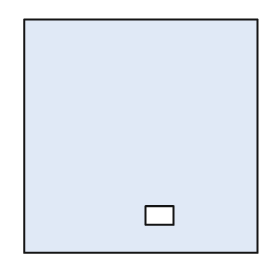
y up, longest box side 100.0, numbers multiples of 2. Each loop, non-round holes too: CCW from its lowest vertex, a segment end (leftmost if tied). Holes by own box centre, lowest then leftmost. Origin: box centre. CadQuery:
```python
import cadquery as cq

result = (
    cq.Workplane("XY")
    .moveTo(-50.0, -50.0)
    .lineTo(50.0, -50.0)
    .lineTo(50.0, 50.0)
    .lineTo(-50.0, 50.0)
    .close()
    .moveTo(2.0, -38.0)
    .lineTo(14.0, -38.0)
    .lineTo(14.0, -30.0)
    .lineTo(2.0, -30.0)
    .close()
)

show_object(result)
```